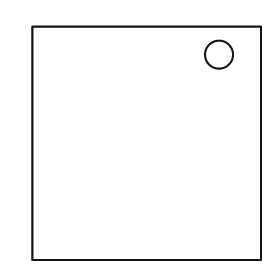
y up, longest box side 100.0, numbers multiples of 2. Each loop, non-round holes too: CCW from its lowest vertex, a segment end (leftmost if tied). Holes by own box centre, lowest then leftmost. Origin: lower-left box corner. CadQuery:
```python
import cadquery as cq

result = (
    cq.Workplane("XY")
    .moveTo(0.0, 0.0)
    .lineTo(98.0, 0.0)
    .lineTo(98.0, 100.0)
    .lineTo(0.0, 100.0)
    .close()
    .moveTo(80.0, 88.0)
    .circle(6.0)
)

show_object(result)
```